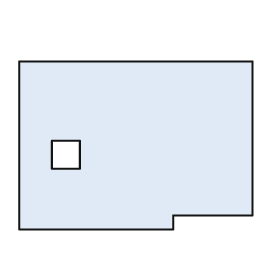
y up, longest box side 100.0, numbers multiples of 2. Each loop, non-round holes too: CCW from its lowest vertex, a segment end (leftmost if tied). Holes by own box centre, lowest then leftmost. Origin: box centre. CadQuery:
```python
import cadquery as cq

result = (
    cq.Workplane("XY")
    .moveTo(-50.0, -36.0)
    .lineTo(16.0, -36.0)
    .lineTo(16.0, -30.0)
    .lineTo(50.0, -30.0)
    .lineTo(50.0, 36.0)
    .lineTo(-50.0, 36.0)
    .close()
    .moveTo(-36.0, -10.0)
    .lineTo(-24.0, -10.0)
    .lineTo(-24.0, 2.0)
    .lineTo(-36.0, 2.0)
    .close()
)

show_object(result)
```